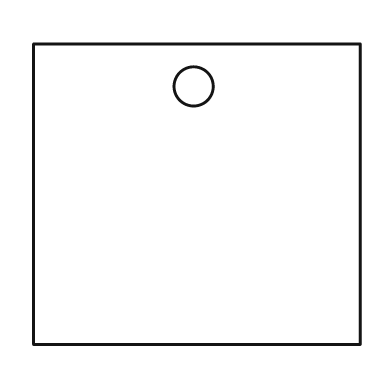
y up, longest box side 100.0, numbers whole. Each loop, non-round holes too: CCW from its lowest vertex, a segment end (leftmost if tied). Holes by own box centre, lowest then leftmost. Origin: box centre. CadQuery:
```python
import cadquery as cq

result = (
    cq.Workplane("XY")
    .moveTo(-50.0, -46.0)
    .lineTo(50.0, -46.0)
    .lineTo(50.0, 46.0)
    .lineTo(-50.0, 46.0)
    .close()
    .moveTo(-1.0, 33.0)
    .circle(6.0)
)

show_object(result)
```